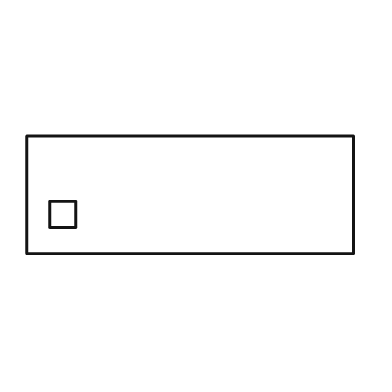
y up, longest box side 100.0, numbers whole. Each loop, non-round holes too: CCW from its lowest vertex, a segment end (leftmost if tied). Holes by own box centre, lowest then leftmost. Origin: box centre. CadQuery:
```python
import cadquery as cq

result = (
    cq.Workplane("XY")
    .moveTo(-50.0, -18.0)
    .lineTo(50.0, -18.0)
    .lineTo(50.0, 18.0)
    .lineTo(-50.0, 18.0)
    .close()
    .moveTo(-43.0, -10.0)
    .lineTo(-35.0, -10.0)
    .lineTo(-35.0, -2.0)
    .lineTo(-43.0, -2.0)
    .close()
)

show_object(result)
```